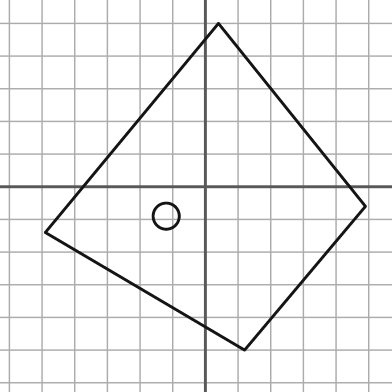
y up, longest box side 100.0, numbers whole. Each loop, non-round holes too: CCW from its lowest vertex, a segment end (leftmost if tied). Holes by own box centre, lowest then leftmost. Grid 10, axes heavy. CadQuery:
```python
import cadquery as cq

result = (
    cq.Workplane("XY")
    .moveTo(12.0, -50.0)
    .lineTo(49.0, -6.0)
    .lineTo(4.0, 50.0)
    .lineTo(-49.0, -14.0)
    .close()
    .moveTo(-12.0, -9.0)
    .circle(4.0)
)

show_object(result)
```